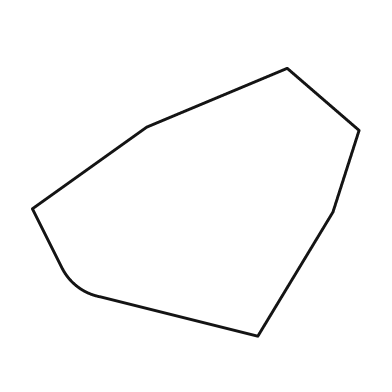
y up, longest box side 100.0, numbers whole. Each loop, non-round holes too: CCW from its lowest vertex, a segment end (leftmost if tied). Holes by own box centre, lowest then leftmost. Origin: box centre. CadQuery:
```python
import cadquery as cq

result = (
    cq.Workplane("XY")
    .moveTo(19.0, -41.0)
    .lineTo(42.0, -3.0)
    .lineTo(50.0, 22.0)
    .lineTo(28.0, 41.0)
    .lineTo(-15.0, 23.0)
    .lineTo(-50.0, -2.0)
    .lineTo(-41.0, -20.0)
    .threePointArc((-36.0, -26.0), (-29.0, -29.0))
    .close()
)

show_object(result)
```